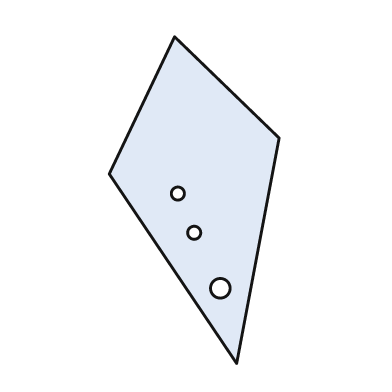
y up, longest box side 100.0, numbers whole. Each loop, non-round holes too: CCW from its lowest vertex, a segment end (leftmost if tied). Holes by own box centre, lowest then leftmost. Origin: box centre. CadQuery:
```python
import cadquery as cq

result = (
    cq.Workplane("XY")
    .moveTo(13.0, -50.0)
    .lineTo(26.0, 19.0)
    .lineTo(-6.0, 50.0)
    .lineTo(-26.0, 8.0)
    .close()
    .moveTo(8.0, -27.0)
    .circle(3.0)
    .moveTo(0.0, -10.0)
    .circle(2.0)
    .moveTo(-5.0, 2.0)
    .circle(2.0)
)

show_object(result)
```